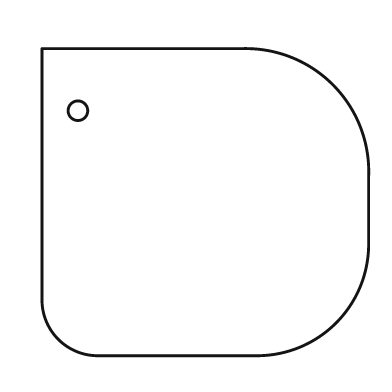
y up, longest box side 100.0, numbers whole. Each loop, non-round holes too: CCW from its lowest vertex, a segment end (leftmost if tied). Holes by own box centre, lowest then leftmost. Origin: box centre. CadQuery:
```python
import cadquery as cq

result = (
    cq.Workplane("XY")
    .moveTo(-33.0, -47.0)
    .lineTo(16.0, -47.0)
    .threePointArc((40.0, -37.0), (50.0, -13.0))
    .lineTo(50.0, 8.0)
    .threePointArc((39.0, 36.0), (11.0, 47.0))
    .lineTo(-50.0, 47.0)
    .lineTo(-50.0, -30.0)
    .threePointArc((-45.0, -42.0), (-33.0, -47.0))
    .close()
    .moveTo(-39.0, 28.0)
    .circle(3.0)
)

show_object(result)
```